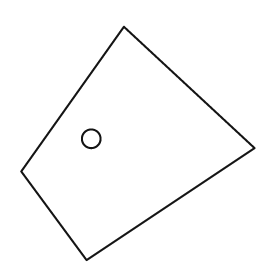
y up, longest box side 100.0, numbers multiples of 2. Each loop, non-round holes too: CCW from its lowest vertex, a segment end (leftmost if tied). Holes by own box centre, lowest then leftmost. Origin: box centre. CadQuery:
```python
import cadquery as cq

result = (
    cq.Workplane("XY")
    .moveTo(-22.0, -50.0)
    .lineTo(50.0, -2.0)
    .lineTo(-6.0, 50.0)
    .lineTo(-50.0, -12.0)
    .close()
    .moveTo(-20.0, 2.0)
    .circle(4.0)
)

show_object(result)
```